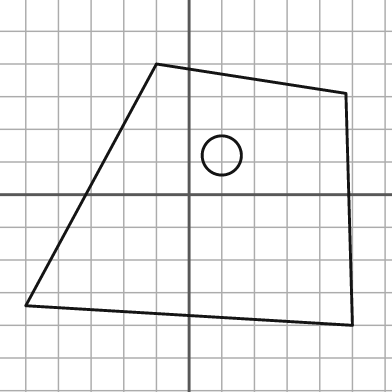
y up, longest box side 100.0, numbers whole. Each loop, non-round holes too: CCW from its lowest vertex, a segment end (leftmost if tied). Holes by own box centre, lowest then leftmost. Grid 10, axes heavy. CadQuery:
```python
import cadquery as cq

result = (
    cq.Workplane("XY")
    .moveTo(50.0, -40.0)
    .lineTo(48.0, 31.0)
    .lineTo(-10.0, 40.0)
    .lineTo(-50.0, -34.0)
    .close()
    .moveTo(10.0, 12.0)
    .circle(6.0)
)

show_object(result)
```